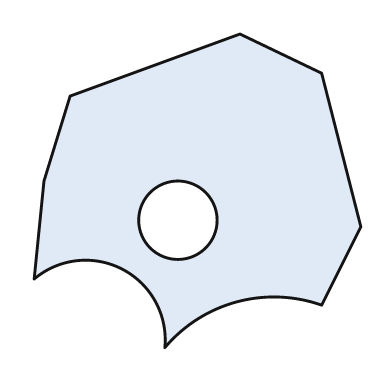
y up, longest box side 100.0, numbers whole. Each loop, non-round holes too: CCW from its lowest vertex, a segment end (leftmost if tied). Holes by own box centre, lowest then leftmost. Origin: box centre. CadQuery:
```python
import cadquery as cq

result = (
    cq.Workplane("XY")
    .moveTo(-10.0, -48.0)
    .threePointArc((12.0, -34.0), (38.0, -35.0))
    .lineTo(50.0, -11.0)
    .lineTo(38.0, 36.0)
    .lineTo(13.0, 48.0)
    .lineTo(-39.0, 29.0)
    .lineTo(-47.0, 3.0)
    .lineTo(-50.0, -27.0)
    .threePointArc((-23.0, -24.0), (-10.0, -48.0))
    .close()
    .moveTo(-6.0, -9.0)
    .circle(12.0)
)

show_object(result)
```